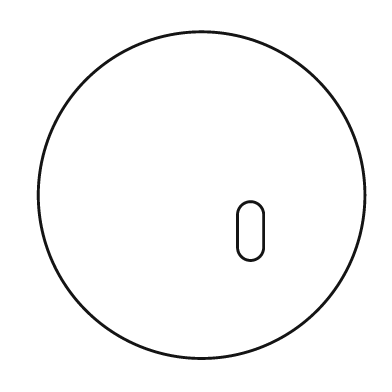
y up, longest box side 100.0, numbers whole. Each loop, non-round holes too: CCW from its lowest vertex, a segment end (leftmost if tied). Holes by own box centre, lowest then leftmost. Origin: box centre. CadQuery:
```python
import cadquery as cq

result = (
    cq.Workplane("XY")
    .moveTo(0.0, 0.0)
    .circle(50.0)
    .moveTo(11.0, -16.0)
    .threePointArc((15.0, -20.0), (19.0, -16.0))
    .lineTo(19.0, -6.0)
    .threePointArc((15.0, -2.0), (11.0, -6.0))
    .close()
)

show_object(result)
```